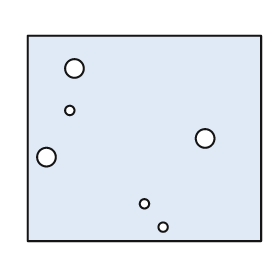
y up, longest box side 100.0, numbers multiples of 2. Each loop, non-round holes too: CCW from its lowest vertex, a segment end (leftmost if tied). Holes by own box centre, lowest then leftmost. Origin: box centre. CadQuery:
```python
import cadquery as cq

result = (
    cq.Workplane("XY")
    .moveTo(-50.0, -44.0)
    .lineTo(50.0, -44.0)
    .lineTo(50.0, 44.0)
    .lineTo(-50.0, 44.0)
    .close()
    .moveTo(8.0, -38.0)
    .circle(2.0)
    .moveTo(0.0, -28.0)
    .circle(2.0)
    .moveTo(-42.0, -8.0)
    .circle(4.0)
    .moveTo(26.0, 0.0)
    .circle(4.0)
    .moveTo(-32.0, 12.0)
    .circle(2.0)
    .moveTo(-30.0, 30.0)
    .circle(4.0)
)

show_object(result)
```